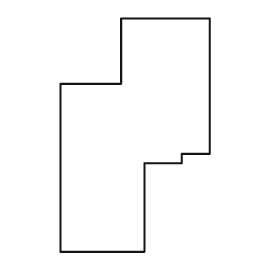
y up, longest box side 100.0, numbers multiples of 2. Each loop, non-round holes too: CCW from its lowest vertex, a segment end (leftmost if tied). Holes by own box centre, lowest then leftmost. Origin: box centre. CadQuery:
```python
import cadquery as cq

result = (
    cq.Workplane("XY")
    .moveTo(-32.0, -50.0)
    .lineTo(4.0, -50.0)
    .lineTo(4.0, -12.0)
    .lineTo(20.0, -12.0)
    .lineTo(20.0, -8.0)
    .lineTo(32.0, -8.0)
    .lineTo(32.0, 50.0)
    .lineTo(-6.0, 50.0)
    .lineTo(-6.0, 22.0)
    .lineTo(-32.0, 22.0)
    .close()
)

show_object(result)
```